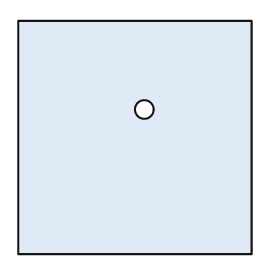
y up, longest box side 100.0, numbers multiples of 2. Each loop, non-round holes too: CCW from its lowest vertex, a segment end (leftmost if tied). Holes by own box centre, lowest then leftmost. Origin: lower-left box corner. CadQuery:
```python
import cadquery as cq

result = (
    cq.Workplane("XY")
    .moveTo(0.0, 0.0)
    .lineTo(100.0, 0.0)
    .lineTo(100.0, 100.0)
    .lineTo(0.0, 100.0)
    .close()
    .moveTo(54.0, 62.0)
    .circle(4.0)
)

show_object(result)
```